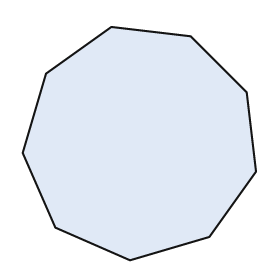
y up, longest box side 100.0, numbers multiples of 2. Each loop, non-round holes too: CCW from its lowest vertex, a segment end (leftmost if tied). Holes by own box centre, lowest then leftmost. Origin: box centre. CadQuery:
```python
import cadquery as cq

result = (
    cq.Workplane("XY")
    .moveTo(-4.0, -50.0)
    .lineTo(30.0, -40.0)
    .lineTo(50.0, -12.0)
    .lineTo(46.0, 22.0)
    .lineTo(22.0, 46.0)
    .lineTo(-12.0, 50.0)
    .lineTo(-40.0, 30.0)
    .lineTo(-50.0, -4.0)
    .lineTo(-36.0, -36.0)
    .close()
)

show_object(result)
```